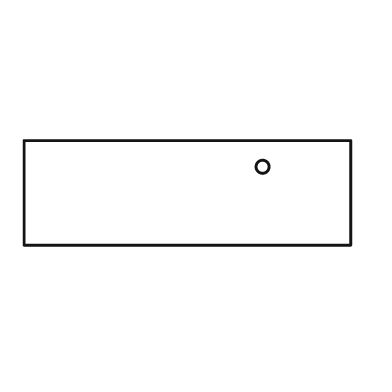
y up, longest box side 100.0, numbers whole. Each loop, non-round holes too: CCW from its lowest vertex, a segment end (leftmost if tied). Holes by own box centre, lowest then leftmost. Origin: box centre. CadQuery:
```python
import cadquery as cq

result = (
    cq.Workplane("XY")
    .moveTo(-50.0, -16.0)
    .lineTo(50.0, -16.0)
    .lineTo(50.0, 16.0)
    .lineTo(-50.0, 16.0)
    .close()
    .moveTo(23.0, 8.0)
    .circle(2.0)
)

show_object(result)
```